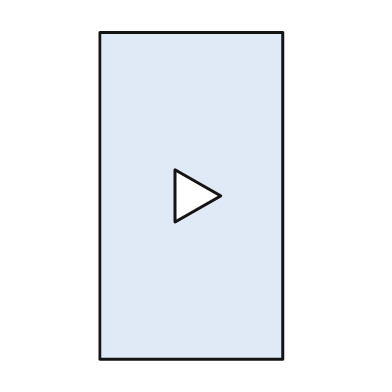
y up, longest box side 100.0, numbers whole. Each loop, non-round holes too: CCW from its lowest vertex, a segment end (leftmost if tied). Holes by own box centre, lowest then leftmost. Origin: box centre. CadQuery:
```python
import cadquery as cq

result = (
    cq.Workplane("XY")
    .moveTo(-28.0, -50.0)
    .lineTo(28.0, -50.0)
    .lineTo(28.0, 50.0)
    .lineTo(-28.0, 50.0)
    .close()
    .moveTo(-5.0, -8.0)
    .lineTo(9.0, 0.0)
    .lineTo(-5.0, 8.0)
    .close()
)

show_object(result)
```